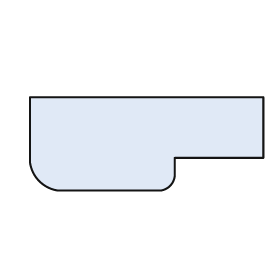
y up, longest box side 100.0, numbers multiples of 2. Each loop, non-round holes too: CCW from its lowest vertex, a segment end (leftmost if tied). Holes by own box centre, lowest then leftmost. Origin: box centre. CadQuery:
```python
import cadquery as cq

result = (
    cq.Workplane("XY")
    .moveTo(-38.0, -20.0)
    .lineTo(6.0, -20.0)
    .threePointArc((10.0, -18.0), (12.0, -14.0))
    .lineTo(12.0, -6.0)
    .lineTo(50.0, -6.0)
    .lineTo(50.0, 20.0)
    .lineTo(-50.0, 20.0)
    .lineTo(-50.0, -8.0)
    .threePointArc((-46.0, -16.0), (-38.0, -20.0))
    .close()
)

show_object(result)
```